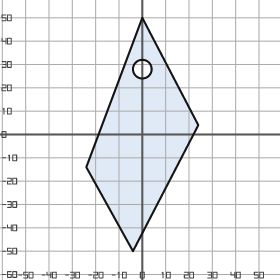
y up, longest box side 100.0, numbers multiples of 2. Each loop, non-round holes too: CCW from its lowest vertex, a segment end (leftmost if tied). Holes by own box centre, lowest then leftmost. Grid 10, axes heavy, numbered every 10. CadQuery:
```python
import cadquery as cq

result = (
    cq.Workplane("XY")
    .moveTo(-4.0, -50.0)
    .lineTo(24.0, 4.0)
    .lineTo(0.0, 50.0)
    .lineTo(-24.0, -14.0)
    .close()
    .moveTo(0.0, 28.0)
    .circle(4.0)
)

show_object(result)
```